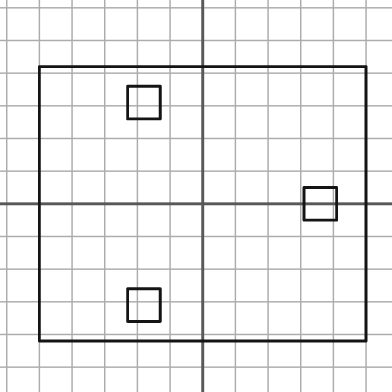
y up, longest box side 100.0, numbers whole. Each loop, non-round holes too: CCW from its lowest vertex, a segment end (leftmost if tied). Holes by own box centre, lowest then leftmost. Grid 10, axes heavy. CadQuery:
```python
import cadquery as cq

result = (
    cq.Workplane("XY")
    .moveTo(-50.0, -42.0)
    .lineTo(50.0, -42.0)
    .lineTo(50.0, 42.0)
    .lineTo(-50.0, 42.0)
    .close()
    .moveTo(-23.0, -36.0)
    .lineTo(-13.0, -36.0)
    .lineTo(-13.0, -26.0)
    .lineTo(-23.0, -26.0)
    .close()
    .moveTo(31.0, -5.0)
    .lineTo(41.0, -5.0)
    .lineTo(41.0, 5.0)
    .lineTo(31.0, 5.0)
    .close()
    .moveTo(-23.0, 26.0)
    .lineTo(-13.0, 26.0)
    .lineTo(-13.0, 36.0)
    .lineTo(-23.0, 36.0)
    .close()
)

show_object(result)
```